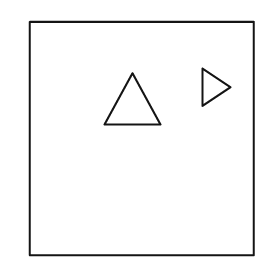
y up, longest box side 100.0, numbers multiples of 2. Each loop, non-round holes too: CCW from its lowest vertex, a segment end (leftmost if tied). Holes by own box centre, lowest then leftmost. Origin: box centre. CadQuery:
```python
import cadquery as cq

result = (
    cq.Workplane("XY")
    .moveTo(-48.0, -50.0)
    .lineTo(48.0, -50.0)
    .lineTo(48.0, 50.0)
    .lineTo(-48.0, 50.0)
    .close()
    .moveTo(-16.0, 6.0)
    .lineTo(8.0, 6.0)
    .lineTo(-4.0, 28.0)
    .close()
    .moveTo(26.0, 14.0)
    .lineTo(38.0, 22.0)
    .lineTo(26.0, 30.0)
    .close()
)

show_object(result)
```